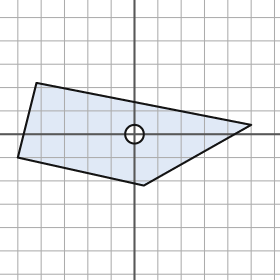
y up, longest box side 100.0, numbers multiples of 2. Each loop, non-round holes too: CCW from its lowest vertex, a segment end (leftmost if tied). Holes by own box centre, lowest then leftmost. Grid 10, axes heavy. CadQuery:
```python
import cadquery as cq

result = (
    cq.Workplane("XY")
    .moveTo(4.0, -22.0)
    .lineTo(50.0, 4.0)
    .lineTo(-42.0, 22.0)
    .lineTo(-50.0, -10.0)
    .close()
    .moveTo(0.0, 0.0)
    .circle(4.0)
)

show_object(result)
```